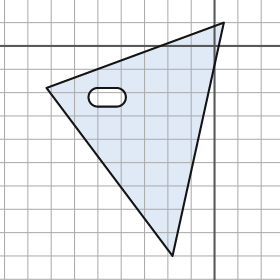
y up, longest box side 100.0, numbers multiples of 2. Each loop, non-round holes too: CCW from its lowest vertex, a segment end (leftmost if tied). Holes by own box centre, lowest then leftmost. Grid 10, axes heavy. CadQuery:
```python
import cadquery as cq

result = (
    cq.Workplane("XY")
    .moveTo(-18.0, -90.0)
    .lineTo(4.0, 10.0)
    .lineTo(-72.0, -18.0)
    .close()
    .moveTo(-50.0, -26.0)
    .lineTo(-42.0, -26.0)
    .threePointArc((-38.0, -22.0), (-42.0, -18.0))
    .lineTo(-50.0, -18.0)
    .threePointArc((-54.0, -22.0), (-50.0, -26.0))
    .close()
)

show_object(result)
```